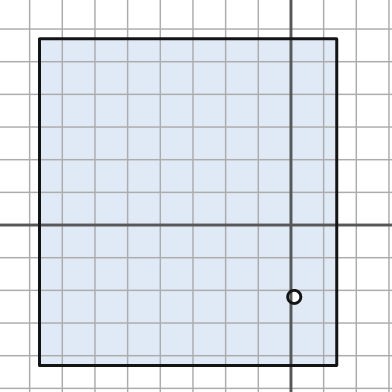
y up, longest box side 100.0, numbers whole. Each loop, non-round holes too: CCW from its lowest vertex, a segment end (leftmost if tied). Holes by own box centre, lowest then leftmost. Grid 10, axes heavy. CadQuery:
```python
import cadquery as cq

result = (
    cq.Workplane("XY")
    .moveTo(-77.0, -43.0)
    .lineTo(14.0, -43.0)
    .lineTo(14.0, 57.0)
    .lineTo(-77.0, 57.0)
    .close()
    .moveTo(1.0, -22.0)
    .circle(2.0)
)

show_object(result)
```